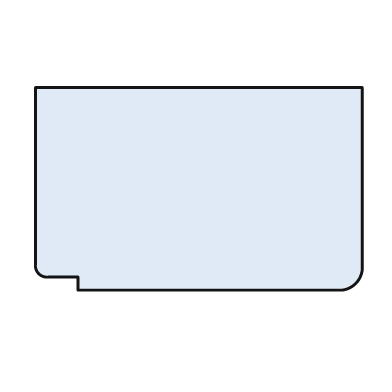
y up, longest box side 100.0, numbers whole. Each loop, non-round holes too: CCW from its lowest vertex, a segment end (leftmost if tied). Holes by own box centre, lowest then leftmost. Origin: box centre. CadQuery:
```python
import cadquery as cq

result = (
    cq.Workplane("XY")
    .moveTo(-37.0, -31.0)
    .lineTo(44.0, -31.0)
    .threePointArc((48.0, -29.0), (50.0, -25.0))
    .lineTo(50.0, 31.0)
    .lineTo(-50.0, 31.0)
    .lineTo(-50.0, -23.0)
    .threePointArc((-49.0, -26.0), (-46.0, -27.0))
    .lineTo(-37.0, -27.0)
    .close()
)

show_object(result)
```